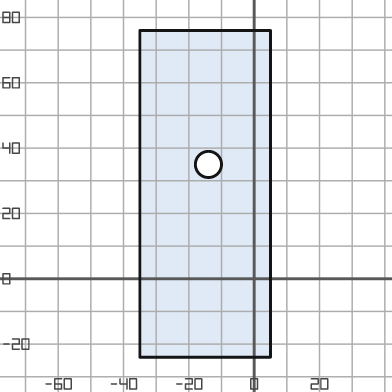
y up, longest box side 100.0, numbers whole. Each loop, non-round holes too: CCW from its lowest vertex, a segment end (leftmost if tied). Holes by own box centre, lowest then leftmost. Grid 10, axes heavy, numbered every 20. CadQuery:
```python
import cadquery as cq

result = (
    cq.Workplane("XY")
    .moveTo(-35.0, -24.0)
    .lineTo(5.0, -24.0)
    .lineTo(5.0, 76.0)
    .lineTo(-35.0, 76.0)
    .close()
    .moveTo(-14.0, 35.0)
    .circle(4.0)
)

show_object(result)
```